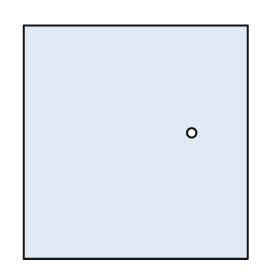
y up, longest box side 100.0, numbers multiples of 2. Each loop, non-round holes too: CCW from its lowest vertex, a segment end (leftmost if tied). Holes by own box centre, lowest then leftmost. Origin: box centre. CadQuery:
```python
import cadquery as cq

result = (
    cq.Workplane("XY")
    .moveTo(-48.0, -50.0)
    .lineTo(48.0, -50.0)
    .lineTo(48.0, 50.0)
    .lineTo(-48.0, 50.0)
    .close()
    .moveTo(24.0, 4.0)
    .circle(2.0)
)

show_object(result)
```